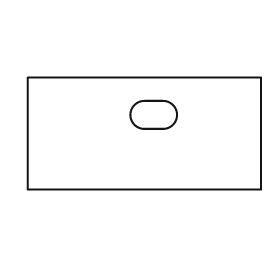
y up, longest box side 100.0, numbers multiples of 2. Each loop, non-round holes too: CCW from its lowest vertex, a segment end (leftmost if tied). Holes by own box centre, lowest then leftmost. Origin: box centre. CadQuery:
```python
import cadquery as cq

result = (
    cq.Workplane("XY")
    .moveTo(-50.0, -24.0)
    .lineTo(50.0, -24.0)
    .lineTo(50.0, 24.0)
    .lineTo(-50.0, 24.0)
    .close()
    .moveTo(0.0, 2.0)
    .lineTo(8.0, 2.0)
    .threePointArc((14.0, 8.0), (8.0, 14.0))
    .lineTo(0.0, 14.0)
    .threePointArc((-6.0, 8.0), (0.0, 2.0))
    .close()
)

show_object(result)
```